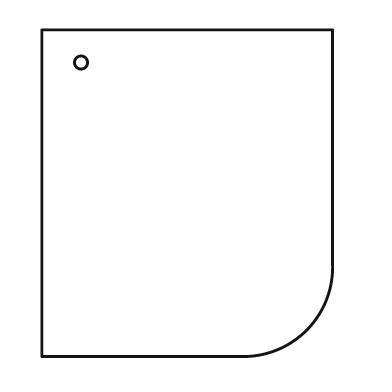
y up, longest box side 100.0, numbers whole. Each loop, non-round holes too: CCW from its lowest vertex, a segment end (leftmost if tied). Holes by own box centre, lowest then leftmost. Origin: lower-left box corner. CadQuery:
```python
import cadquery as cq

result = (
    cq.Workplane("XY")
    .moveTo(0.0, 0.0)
    .lineTo(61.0, 0.0)
    .threePointArc((81.0, 8.0), (89.0, 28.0))
    .lineTo(89.0, 100.0)
    .lineTo(0.0, 100.0)
    .close()
    .moveTo(12.0, 90.0)
    .circle(2.0)
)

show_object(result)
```